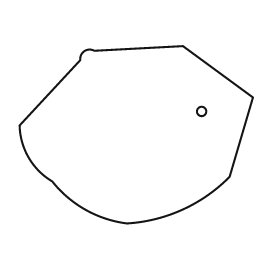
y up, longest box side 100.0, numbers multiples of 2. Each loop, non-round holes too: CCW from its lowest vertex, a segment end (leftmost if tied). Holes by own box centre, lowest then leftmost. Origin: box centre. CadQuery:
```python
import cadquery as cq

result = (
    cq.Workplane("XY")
    .moveTo(-4.0, -38.0)
    .threePointArc((20.0, -32.0), (40.0, -18.0))
    .lineTo(50.0, 16.0)
    .lineTo(20.0, 38.0)
    .lineTo(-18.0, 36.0)
    .threePointArc((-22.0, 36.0), (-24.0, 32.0))
    .lineTo(-50.0, 4.0)
    .threePointArc((-46.0, -10.0), (-36.0, -20.0))
    .threePointArc((-22.0, -32.0), (-4.0, -38.0))
    .close()
    .moveTo(28.0, 10.0)
    .circle(2.0)
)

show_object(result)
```